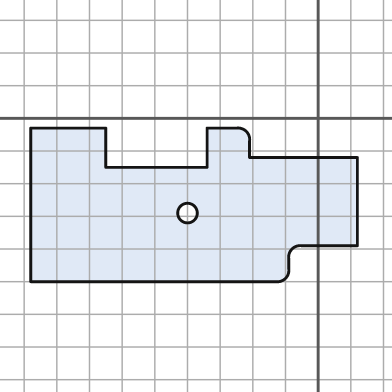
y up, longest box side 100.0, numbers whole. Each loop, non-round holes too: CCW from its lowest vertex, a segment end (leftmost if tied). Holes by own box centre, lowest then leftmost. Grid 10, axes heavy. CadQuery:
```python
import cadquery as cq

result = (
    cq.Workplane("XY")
    .moveTo(-88.0, -50.0)
    .lineTo(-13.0, -50.0)
    .threePointArc((-10.0, -49.0), (-9.0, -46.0))
    .lineTo(-9.0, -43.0)
    .threePointArc((-8.0, -40.0), (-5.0, -39.0))
    .lineTo(12.0, -39.0)
    .lineTo(12.0, -12.0)
    .lineTo(-21.0, -12.0)
    .lineTo(-21.0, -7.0)
    .threePointArc((-22.0, -4.0), (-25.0, -3.0))
    .lineTo(-34.0, -3.0)
    .lineTo(-34.0, -15.0)
    .lineTo(-65.0, -15.0)
    .lineTo(-65.0, -3.0)
    .lineTo(-88.0, -3.0)
    .close()
    .moveTo(-40.0, -29.0)
    .circle(3.0)
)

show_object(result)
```